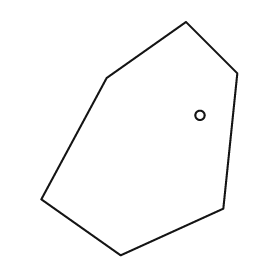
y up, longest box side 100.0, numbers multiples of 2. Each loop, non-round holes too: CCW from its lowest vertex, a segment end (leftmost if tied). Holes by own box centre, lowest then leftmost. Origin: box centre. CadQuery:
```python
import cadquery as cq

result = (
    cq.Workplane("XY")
    .moveTo(-8.0, -50.0)
    .lineTo(36.0, -30.0)
    .lineTo(42.0, 28.0)
    .lineTo(20.0, 50.0)
    .lineTo(-14.0, 26.0)
    .lineTo(-42.0, -26.0)
    .close()
    .moveTo(26.0, 10.0)
    .circle(2.0)
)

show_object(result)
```